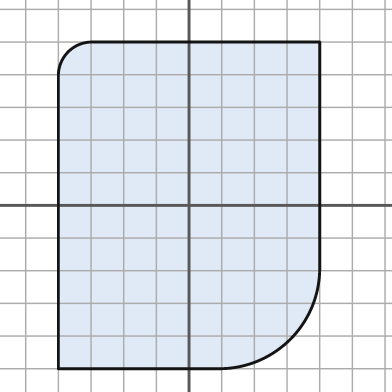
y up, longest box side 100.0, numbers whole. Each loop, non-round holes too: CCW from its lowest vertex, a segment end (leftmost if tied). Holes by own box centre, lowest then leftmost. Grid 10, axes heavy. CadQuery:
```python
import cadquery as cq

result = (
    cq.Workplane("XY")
    .moveTo(-40.0, -50.0)
    .lineTo(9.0, -50.0)
    .threePointArc((31.0, -41.0), (40.0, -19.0))
    .lineTo(40.0, 50.0)
    .lineTo(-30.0, 50.0)
    .threePointArc((-37.0, 47.0), (-40.0, 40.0))
    .close()
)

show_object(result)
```